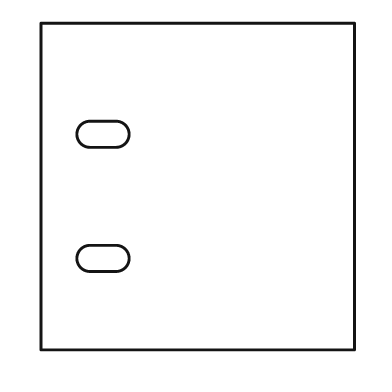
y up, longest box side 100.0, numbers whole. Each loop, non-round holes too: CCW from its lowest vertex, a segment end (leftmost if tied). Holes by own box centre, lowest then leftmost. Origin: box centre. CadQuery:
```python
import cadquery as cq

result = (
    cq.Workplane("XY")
    .moveTo(-48.0, -50.0)
    .lineTo(48.0, -50.0)
    .lineTo(48.0, 50.0)
    .lineTo(-48.0, 50.0)
    .close()
    .moveTo(-33.0, -26.0)
    .lineTo(-25.0, -26.0)
    .threePointArc((-21.0, -22.0), (-25.0, -18.0))
    .lineTo(-33.0, -18.0)
    .threePointArc((-37.0, -22.0), (-33.0, -26.0))
    .close()
    .moveTo(-33.0, 12.0)
    .lineTo(-25.0, 12.0)
    .threePointArc((-21.0, 16.0), (-25.0, 20.0))
    .lineTo(-33.0, 20.0)
    .threePointArc((-37.0, 16.0), (-33.0, 12.0))
    .close()
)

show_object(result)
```